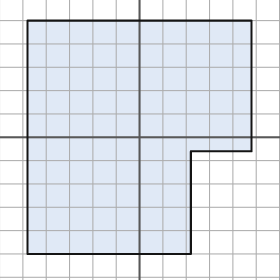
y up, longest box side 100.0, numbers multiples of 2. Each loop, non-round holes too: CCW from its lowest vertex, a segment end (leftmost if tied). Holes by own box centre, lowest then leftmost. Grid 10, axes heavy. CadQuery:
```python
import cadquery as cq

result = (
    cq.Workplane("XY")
    .moveTo(-48.0, -50.0)
    .lineTo(22.0, -50.0)
    .lineTo(22.0, -6.0)
    .lineTo(48.0, -6.0)
    .lineTo(48.0, 50.0)
    .lineTo(-48.0, 50.0)
    .close()
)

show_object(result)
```